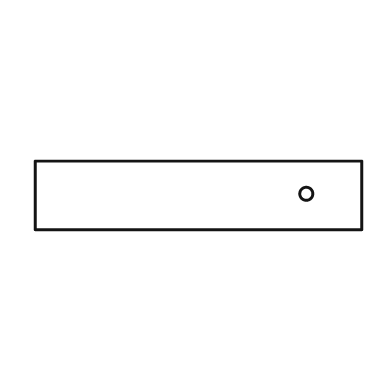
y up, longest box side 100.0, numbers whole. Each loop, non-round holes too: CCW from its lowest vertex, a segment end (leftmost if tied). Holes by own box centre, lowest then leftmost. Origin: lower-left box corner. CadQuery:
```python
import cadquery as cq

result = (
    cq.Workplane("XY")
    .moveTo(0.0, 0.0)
    .lineTo(100.0, 0.0)
    .lineTo(100.0, 21.0)
    .lineTo(0.0, 21.0)
    .close()
    .moveTo(83.0, 11.0)
    .circle(2.0)
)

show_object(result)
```